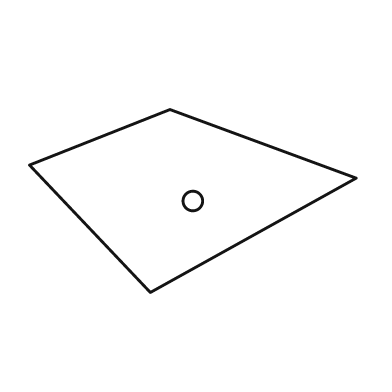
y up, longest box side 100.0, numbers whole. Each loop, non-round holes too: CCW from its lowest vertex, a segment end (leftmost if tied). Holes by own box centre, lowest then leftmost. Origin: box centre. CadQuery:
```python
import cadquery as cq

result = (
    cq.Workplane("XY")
    .moveTo(-13.0, -28.0)
    .lineTo(50.0, 7.0)
    .lineTo(-7.0, 28.0)
    .lineTo(-50.0, 11.0)
    .close()
    .moveTo(0.0, 0.0)
    .circle(3.0)
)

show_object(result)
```